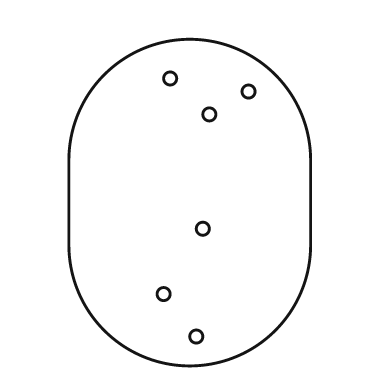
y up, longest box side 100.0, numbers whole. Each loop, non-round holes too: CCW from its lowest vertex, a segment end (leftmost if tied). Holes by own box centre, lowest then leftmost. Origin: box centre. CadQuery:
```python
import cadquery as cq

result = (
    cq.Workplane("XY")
    .moveTo(-37.0, -13.0)
    .threePointArc((0.0, -50.0), (37.0, -13.0))
    .lineTo(37.0, 13.0)
    .threePointArc((0.0, 50.0), (-37.0, 13.0))
    .close()
    .moveTo(2.0, -41.0)
    .circle(2.0)
    .moveTo(-8.0, -28.0)
    .circle(2.0)
    .moveTo(4.0, -8.0)
    .circle(2.0)
    .moveTo(6.0, 27.0)
    .circle(2.0)
    .moveTo(18.0, 34.0)
    .circle(2.0)
    .moveTo(-6.0, 38.0)
    .circle(2.0)
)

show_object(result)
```